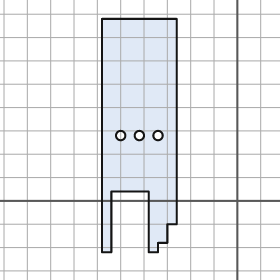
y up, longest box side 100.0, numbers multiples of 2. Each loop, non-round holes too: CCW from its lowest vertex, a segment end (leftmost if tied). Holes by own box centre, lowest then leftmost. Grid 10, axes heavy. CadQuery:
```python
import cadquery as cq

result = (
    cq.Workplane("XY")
    .moveTo(-58.0, -22.0)
    .lineTo(-54.0, -22.0)
    .lineTo(-54.0, 4.0)
    .lineTo(-38.0, 4.0)
    .lineTo(-38.0, -22.0)
    .lineTo(-34.0, -22.0)
    .lineTo(-34.0, -18.0)
    .lineTo(-30.0, -18.0)
    .lineTo(-30.0, -10.0)
    .lineTo(-26.0, -10.0)
    .lineTo(-26.0, 78.0)
    .lineTo(-58.0, 78.0)
    .close()
    .moveTo(-50.0, 28.0)
    .circle(2.0)
    .moveTo(-42.0, 28.0)
    .circle(2.0)
    .moveTo(-34.0, 28.0)
    .circle(2.0)
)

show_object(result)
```